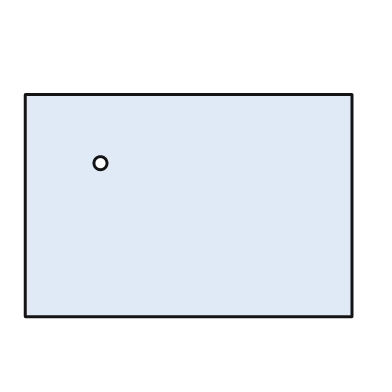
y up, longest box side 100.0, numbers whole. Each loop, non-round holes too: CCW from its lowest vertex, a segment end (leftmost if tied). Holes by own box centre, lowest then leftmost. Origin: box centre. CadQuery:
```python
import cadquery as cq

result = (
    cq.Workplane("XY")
    .moveTo(-50.0, -34.0)
    .lineTo(50.0, -34.0)
    .lineTo(50.0, 34.0)
    .lineTo(-50.0, 34.0)
    .close()
    .moveTo(-27.0, 13.0)
    .circle(2.0)
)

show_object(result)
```